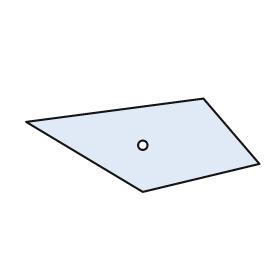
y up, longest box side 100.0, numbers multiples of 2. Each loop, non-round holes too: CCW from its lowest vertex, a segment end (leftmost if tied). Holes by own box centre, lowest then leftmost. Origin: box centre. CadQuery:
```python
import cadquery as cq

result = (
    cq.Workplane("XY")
    .moveTo(0.0, -20.0)
    .lineTo(50.0, -8.0)
    .lineTo(26.0, 20.0)
    .lineTo(-50.0, 10.0)
    .close()
    .moveTo(0.0, 0.0)
    .circle(2.0)
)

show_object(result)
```